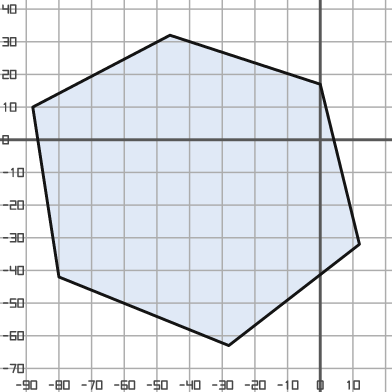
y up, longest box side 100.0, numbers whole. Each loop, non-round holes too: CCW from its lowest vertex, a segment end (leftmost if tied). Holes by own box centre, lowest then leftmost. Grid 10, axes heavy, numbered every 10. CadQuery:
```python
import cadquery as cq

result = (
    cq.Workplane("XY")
    .moveTo(-28.0, -63.0)
    .lineTo(12.0, -32.0)
    .lineTo(0.0, 17.0)
    .lineTo(-46.0, 32.0)
    .lineTo(-88.0, 10.0)
    .lineTo(-80.0, -42.0)
    .close()
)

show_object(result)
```